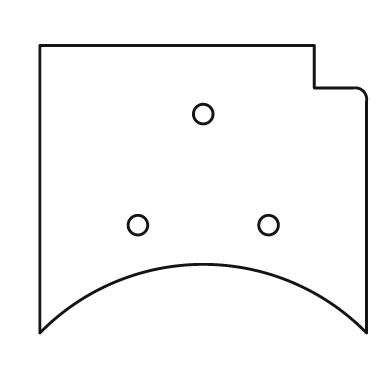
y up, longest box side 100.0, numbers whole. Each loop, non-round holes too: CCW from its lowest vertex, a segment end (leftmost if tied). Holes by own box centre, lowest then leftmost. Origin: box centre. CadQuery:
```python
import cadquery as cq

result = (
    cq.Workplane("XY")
    .moveTo(-50.0, -44.0)
    .threePointArc((0.0, -23.0), (50.0, -44.0))
    .lineTo(50.0, 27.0)
    .threePointArc((49.0, 30.0), (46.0, 31.0))
    .lineTo(34.0, 31.0)
    .lineTo(34.0, 44.0)
    .lineTo(-50.0, 44.0)
    .close()
    .moveTo(-20.0, -11.0)
    .circle(3.0)
    .moveTo(20.0, -11.0)
    .circle(3.0)
    .moveTo(0.0, 23.0)
    .circle(3.0)
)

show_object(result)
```